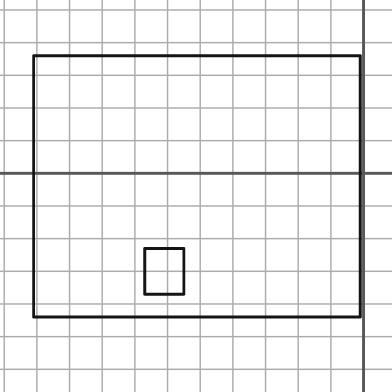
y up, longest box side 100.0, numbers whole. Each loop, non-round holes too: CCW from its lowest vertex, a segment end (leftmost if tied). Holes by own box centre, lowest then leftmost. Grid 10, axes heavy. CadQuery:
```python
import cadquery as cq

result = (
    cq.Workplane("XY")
    .moveTo(-101.0, -44.0)
    .lineTo(-1.0, -44.0)
    .lineTo(-1.0, 36.0)
    .lineTo(-101.0, 36.0)
    .close()
    .moveTo(-67.0, -37.0)
    .lineTo(-55.0, -37.0)
    .lineTo(-55.0, -23.0)
    .lineTo(-67.0, -23.0)
    .close()
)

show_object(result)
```